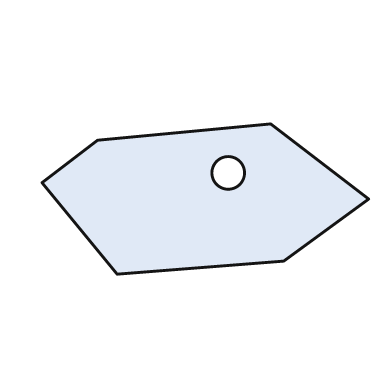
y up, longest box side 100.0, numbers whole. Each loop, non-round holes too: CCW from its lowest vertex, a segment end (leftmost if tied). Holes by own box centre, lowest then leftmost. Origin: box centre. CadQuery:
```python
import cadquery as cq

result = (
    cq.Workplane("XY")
    .moveTo(-27.0, -23.0)
    .lineTo(24.0, -19.0)
    .lineTo(50.0, 0.0)
    .lineTo(20.0, 23.0)
    .lineTo(-33.0, 18.0)
    .lineTo(-50.0, 5.0)
    .close()
    .moveTo(7.0, 8.0)
    .circle(5.0)
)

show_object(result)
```